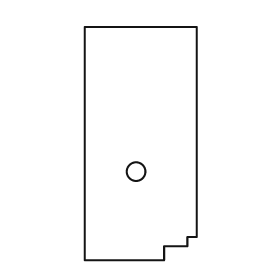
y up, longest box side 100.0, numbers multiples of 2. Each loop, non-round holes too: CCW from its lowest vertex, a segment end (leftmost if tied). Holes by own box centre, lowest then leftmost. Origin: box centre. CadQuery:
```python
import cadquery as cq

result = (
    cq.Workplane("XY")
    .moveTo(-24.0, -50.0)
    .lineTo(10.0, -50.0)
    .lineTo(10.0, -44.0)
    .lineTo(20.0, -44.0)
    .lineTo(20.0, -40.0)
    .lineTo(24.0, -40.0)
    .lineTo(24.0, 50.0)
    .lineTo(-24.0, 50.0)
    .close()
    .moveTo(-2.0, -12.0)
    .circle(4.0)
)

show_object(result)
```